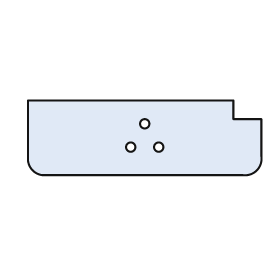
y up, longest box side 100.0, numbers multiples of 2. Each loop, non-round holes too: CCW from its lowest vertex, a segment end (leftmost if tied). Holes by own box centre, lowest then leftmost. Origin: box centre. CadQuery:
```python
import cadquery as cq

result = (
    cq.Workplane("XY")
    .moveTo(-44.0, -16.0)
    .lineTo(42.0, -16.0)
    .threePointArc((48.0, -14.0), (50.0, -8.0))
    .lineTo(50.0, 8.0)
    .lineTo(38.0, 8.0)
    .lineTo(38.0, 16.0)
    .lineTo(-50.0, 16.0)
    .lineTo(-50.0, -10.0)
    .threePointArc((-48.0, -14.0), (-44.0, -16.0))
    .close()
    .moveTo(-6.0, -4.0)
    .circle(2.0)
    .moveTo(6.0, -4.0)
    .circle(2.0)
    .moveTo(0.0, 6.0)
    .circle(2.0)
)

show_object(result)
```